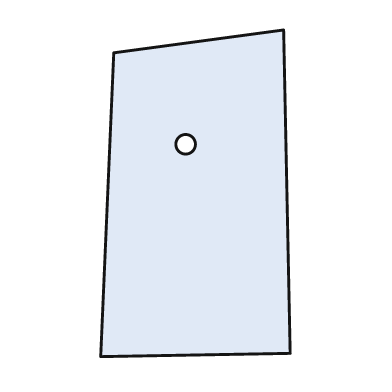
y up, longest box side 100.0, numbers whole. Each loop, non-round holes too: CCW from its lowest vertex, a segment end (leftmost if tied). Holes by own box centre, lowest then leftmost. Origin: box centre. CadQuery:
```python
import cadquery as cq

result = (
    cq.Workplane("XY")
    .moveTo(-29.0, -50.0)
    .lineTo(29.0, -49.0)
    .lineTo(27.0, 50.0)
    .lineTo(-25.0, 43.0)
    .close()
    .moveTo(-3.0, 15.0)
    .circle(3.0)
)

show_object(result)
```